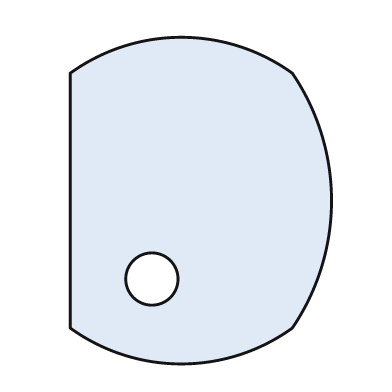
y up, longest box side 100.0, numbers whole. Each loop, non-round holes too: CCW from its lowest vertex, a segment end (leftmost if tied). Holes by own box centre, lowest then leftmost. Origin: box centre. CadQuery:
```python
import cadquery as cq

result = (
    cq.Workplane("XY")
    .moveTo(-40.0, -39.0)
    .threePointArc((-6.0, -50.0), (28.0, -39.0))
    .threePointArc((40.0, 0.0), (28.0, 39.0))
    .threePointArc((-6.0, 50.0), (-40.0, 39.0))
    .close()
    .moveTo(-15.0, -24.0)
    .circle(8.0)
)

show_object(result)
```